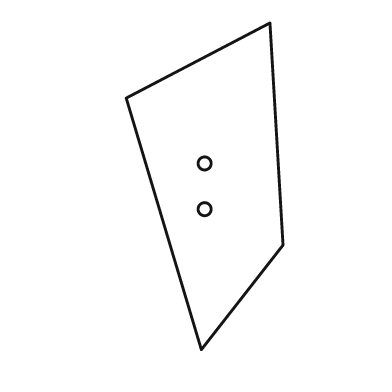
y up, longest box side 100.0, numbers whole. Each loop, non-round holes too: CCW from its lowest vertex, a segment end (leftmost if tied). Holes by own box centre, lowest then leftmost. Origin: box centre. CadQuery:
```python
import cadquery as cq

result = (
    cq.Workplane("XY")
    .moveTo(-1.0, -50.0)
    .lineTo(24.0, -18.0)
    .lineTo(20.0, 50.0)
    .lineTo(-24.0, 27.0)
    .close()
    .moveTo(0.0, -7.0)
    .circle(2.0)
    .moveTo(0.0, 7.0)
    .circle(2.0)
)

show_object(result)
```